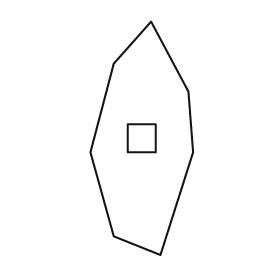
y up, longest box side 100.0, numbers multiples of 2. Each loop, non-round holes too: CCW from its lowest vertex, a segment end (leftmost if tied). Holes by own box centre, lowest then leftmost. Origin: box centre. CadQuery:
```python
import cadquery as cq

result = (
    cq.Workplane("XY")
    .moveTo(8.0, -50.0)
    .lineTo(22.0, -6.0)
    .lineTo(20.0, 20.0)
    .lineTo(4.0, 50.0)
    .lineTo(-12.0, 32.0)
    .lineTo(-22.0, -6.0)
    .lineTo(-12.0, -42.0)
    .close()
    .moveTo(-6.0, -6.0)
    .lineTo(6.0, -6.0)
    .lineTo(6.0, 6.0)
    .lineTo(-6.0, 6.0)
    .close()
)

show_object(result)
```